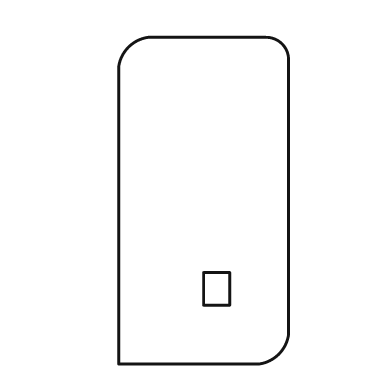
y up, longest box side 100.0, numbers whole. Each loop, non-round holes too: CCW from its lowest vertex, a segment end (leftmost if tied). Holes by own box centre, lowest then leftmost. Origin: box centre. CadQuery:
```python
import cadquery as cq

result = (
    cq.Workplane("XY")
    .moveTo(-26.0, -50.0)
    .lineTo(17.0, -50.0)
    .threePointArc((23.0, -47.0), (26.0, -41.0))
    .lineTo(26.0, 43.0)
    .threePointArc((24.0, 48.0), (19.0, 50.0))
    .lineTo(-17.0, 50.0)
    .threePointArc((-23.0, 47.0), (-26.0, 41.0))
    .close()
    .moveTo(0.0, -32.0)
    .lineTo(8.0, -32.0)
    .lineTo(8.0, -22.0)
    .lineTo(0.0, -22.0)
    .close()
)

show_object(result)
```